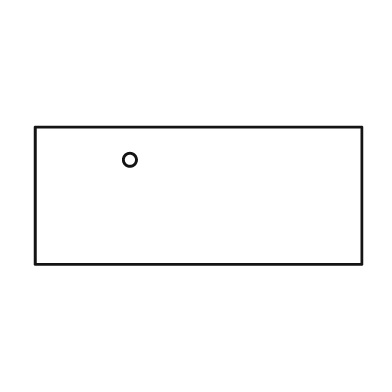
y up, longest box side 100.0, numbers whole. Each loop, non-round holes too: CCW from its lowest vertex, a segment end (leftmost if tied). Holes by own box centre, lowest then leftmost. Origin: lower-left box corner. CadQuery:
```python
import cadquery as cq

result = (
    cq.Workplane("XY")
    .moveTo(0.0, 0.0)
    .lineTo(100.0, 0.0)
    .lineTo(100.0, 42.0)
    .lineTo(0.0, 42.0)
    .close()
    .moveTo(29.0, 32.0)
    .circle(2.0)
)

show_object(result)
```